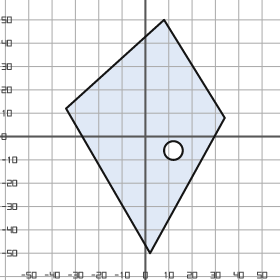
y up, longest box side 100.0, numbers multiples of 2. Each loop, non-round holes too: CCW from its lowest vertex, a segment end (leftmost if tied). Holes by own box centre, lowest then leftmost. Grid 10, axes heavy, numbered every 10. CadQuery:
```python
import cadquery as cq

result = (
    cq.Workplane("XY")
    .moveTo(2.0, -50.0)
    .lineTo(34.0, 8.0)
    .lineTo(8.0, 50.0)
    .lineTo(-34.0, 12.0)
    .close()
    .moveTo(12.0, -6.0)
    .circle(4.0)
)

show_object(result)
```